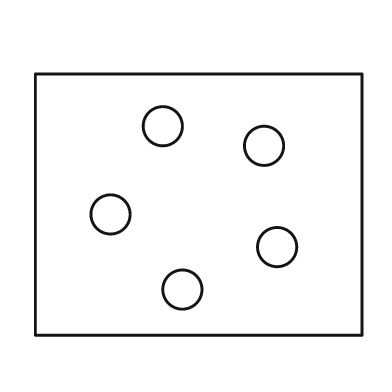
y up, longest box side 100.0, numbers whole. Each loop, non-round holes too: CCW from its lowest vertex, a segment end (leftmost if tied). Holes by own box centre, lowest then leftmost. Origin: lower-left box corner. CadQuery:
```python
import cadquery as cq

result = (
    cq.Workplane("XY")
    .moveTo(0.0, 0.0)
    .lineTo(100.0, 0.0)
    .lineTo(100.0, 80.0)
    .lineTo(0.0, 80.0)
    .close()
    .moveTo(45.0, 14.0)
    .circle(6.0)
    .moveTo(74.0, 27.0)
    .circle(6.0)
    .moveTo(23.0, 37.0)
    .circle(6.0)
    .moveTo(70.0, 58.0)
    .circle(6.0)
    .moveTo(39.0, 64.0)
    .circle(6.0)
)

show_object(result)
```